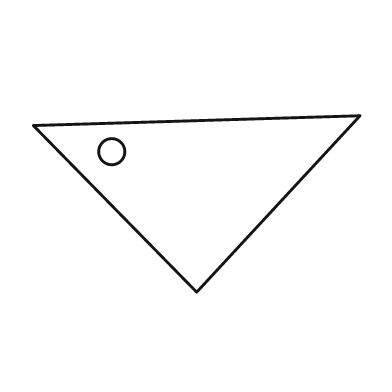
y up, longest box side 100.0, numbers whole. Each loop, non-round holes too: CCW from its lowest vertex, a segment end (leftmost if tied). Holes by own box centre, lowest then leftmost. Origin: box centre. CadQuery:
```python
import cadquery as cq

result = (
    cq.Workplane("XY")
    .moveTo(0.0, -27.0)
    .lineTo(50.0, 27.0)
    .lineTo(-50.0, 24.0)
    .close()
    .moveTo(-26.0, 16.0)
    .circle(4.0)
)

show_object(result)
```